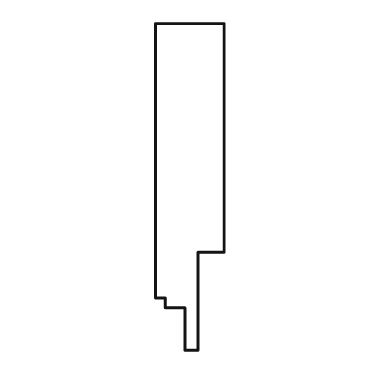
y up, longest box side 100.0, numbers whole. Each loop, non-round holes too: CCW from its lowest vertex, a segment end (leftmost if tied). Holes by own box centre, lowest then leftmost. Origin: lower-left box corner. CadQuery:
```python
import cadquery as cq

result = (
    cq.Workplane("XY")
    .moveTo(9.0, 0.0)
    .lineTo(13.0, 0.0)
    .lineTo(13.0, 30.0)
    .lineTo(21.0, 30.0)
    .lineTo(21.0, 100.0)
    .lineTo(0.0, 100.0)
    .lineTo(0.0, 16.0)
    .lineTo(3.0, 16.0)
    .lineTo(3.0, 13.0)
    .lineTo(9.0, 13.0)
    .close()
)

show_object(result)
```